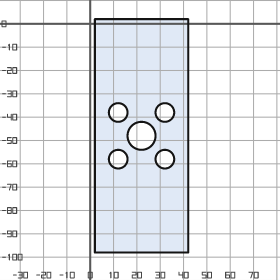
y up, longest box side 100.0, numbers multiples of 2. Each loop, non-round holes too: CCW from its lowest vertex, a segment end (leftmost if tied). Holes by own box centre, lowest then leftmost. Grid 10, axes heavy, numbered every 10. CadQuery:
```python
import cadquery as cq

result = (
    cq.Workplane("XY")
    .moveTo(2.0, -98.0)
    .lineTo(42.0, -98.0)
    .lineTo(42.0, 2.0)
    .lineTo(2.0, 2.0)
    .close()
    .moveTo(12.0, -58.0)
    .circle(4.0)
    .moveTo(32.0, -58.0)
    .circle(4.0)
    .moveTo(22.0, -48.0)
    .circle(6.0)
    .moveTo(12.0, -38.0)
    .circle(4.0)
    .moveTo(32.0, -38.0)
    .circle(4.0)
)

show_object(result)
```